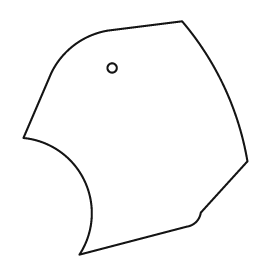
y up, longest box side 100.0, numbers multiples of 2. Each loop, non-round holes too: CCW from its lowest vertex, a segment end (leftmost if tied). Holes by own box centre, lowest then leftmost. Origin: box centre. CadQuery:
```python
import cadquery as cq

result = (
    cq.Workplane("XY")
    .moveTo(-24.0, -50.0)
    .lineTo(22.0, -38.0)
    .threePointArc((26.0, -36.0), (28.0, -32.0))
    .lineTo(48.0, -10.0)
    .threePointArc((38.0, 22.0), (20.0, 50.0))
    .lineTo(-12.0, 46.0)
    .threePointArc((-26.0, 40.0), (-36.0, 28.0))
    .lineTo(-48.0, 0.0)
    .threePointArc((-22.0, -18.0), (-24.0, -50.0))
    .close()
    .moveTo(-10.0, 30.0)
    .circle(2.0)
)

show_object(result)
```